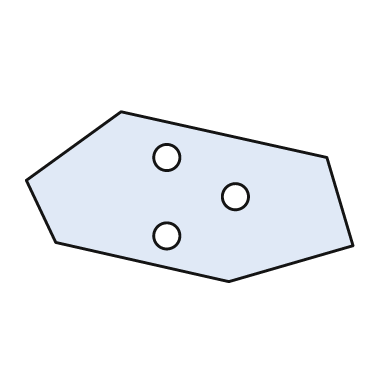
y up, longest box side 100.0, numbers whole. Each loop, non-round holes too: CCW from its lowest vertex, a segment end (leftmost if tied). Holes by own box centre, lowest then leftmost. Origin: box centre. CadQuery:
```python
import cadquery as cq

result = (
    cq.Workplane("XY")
    .moveTo(12.0, -26.0)
    .lineTo(50.0, -15.0)
    .lineTo(42.0, 12.0)
    .lineTo(-21.0, 26.0)
    .lineTo(-50.0, 5.0)
    .lineTo(-41.0, -14.0)
    .close()
    .moveTo(-7.0, -12.0)
    .circle(4.0)
    .moveTo(14.0, 0.0)
    .circle(4.0)
    .moveTo(-7.0, 12.0)
    .circle(4.0)
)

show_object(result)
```